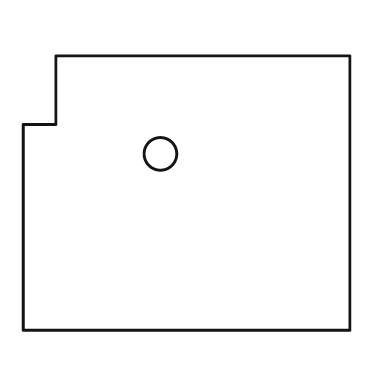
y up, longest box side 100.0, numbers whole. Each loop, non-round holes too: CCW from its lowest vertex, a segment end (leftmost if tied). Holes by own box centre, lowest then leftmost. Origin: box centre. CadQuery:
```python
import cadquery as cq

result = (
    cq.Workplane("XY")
    .moveTo(-50.0, -42.0)
    .lineTo(50.0, -42.0)
    .lineTo(50.0, 42.0)
    .lineTo(-40.0, 42.0)
    .lineTo(-40.0, 21.0)
    .lineTo(-50.0, 21.0)
    .close()
    .moveTo(-8.0, 12.0)
    .circle(5.0)
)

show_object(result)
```